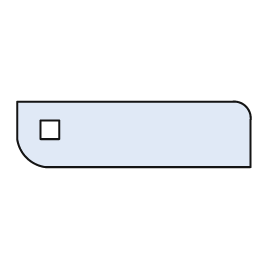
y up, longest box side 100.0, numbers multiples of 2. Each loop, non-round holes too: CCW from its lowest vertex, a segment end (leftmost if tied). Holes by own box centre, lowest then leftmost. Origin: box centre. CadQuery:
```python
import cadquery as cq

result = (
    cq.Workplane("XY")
    .moveTo(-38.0, -14.0)
    .lineTo(50.0, -14.0)
    .lineTo(50.0, 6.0)
    .threePointArc((48.0, 12.0), (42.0, 14.0))
    .lineTo(-50.0, 14.0)
    .lineTo(-50.0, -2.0)
    .threePointArc((-46.0, -10.0), (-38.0, -14.0))
    .close()
    .moveTo(-40.0, -2.0)
    .lineTo(-32.0, -2.0)
    .lineTo(-32.0, 6.0)
    .lineTo(-40.0, 6.0)
    .close()
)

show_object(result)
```